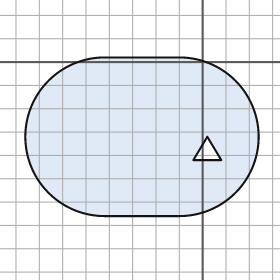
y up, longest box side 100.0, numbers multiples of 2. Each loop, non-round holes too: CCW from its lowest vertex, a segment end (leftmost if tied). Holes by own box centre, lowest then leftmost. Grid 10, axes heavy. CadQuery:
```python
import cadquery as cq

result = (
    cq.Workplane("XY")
    .moveTo(-42.0, -66.0)
    .lineTo(-10.0, -66.0)
    .threePointArc((24.0, -32.0), (-10.0, 2.0))
    .lineTo(-42.0, 2.0)
    .threePointArc((-76.0, -32.0), (-42.0, -66.0))
    .close()
    .moveTo(-4.0, -42.0)
    .lineTo(8.0, -42.0)
    .lineTo(2.0, -32.0)
    .close()
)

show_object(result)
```